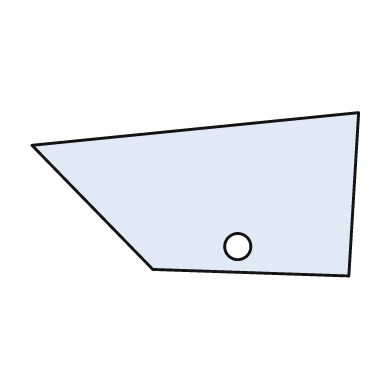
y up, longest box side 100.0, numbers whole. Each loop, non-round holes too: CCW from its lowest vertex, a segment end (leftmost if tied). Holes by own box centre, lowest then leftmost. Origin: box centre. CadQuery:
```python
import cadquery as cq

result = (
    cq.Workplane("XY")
    .moveTo(47.0, -25.0)
    .lineTo(50.0, 25.0)
    .lineTo(-50.0, 15.0)
    .lineTo(-13.0, -23.0)
    .close()
    .moveTo(13.0, -16.0)
    .circle(4.0)
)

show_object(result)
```